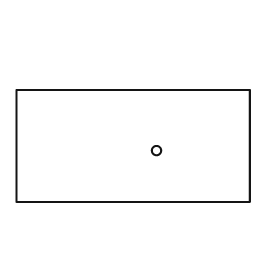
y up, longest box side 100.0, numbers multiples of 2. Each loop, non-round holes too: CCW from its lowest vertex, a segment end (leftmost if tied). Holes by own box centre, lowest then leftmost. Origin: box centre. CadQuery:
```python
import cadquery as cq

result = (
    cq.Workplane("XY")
    .moveTo(-50.0, -24.0)
    .lineTo(50.0, -24.0)
    .lineTo(50.0, 24.0)
    .lineTo(-50.0, 24.0)
    .close()
    .moveTo(10.0, -2.0)
    .circle(2.0)
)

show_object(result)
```